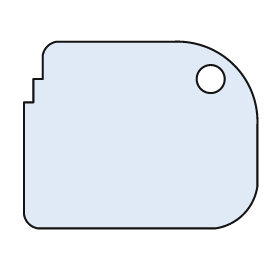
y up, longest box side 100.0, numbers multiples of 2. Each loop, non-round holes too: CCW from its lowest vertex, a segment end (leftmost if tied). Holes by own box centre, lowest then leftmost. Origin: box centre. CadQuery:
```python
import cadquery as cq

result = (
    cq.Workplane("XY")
    .moveTo(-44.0, -40.0)
    .lineTo(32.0, -40.0)
    .threePointArc((44.0, -34.0), (50.0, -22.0))
    .lineTo(50.0, 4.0)
    .threePointArc((40.0, 30.0), (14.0, 40.0))
    .lineTo(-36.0, 40.0)
    .threePointArc((-40.0, 38.0), (-42.0, 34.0))
    .lineTo(-42.0, 24.0)
    .lineTo(-46.0, 24.0)
    .lineTo(-46.0, 14.0)
    .lineTo(-50.0, 14.0)
    .lineTo(-50.0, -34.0)
    .threePointArc((-48.0, -38.0), (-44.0, -40.0))
    .close()
    .moveTo(30.0, 24.0)
    .circle(6.0)
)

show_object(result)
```